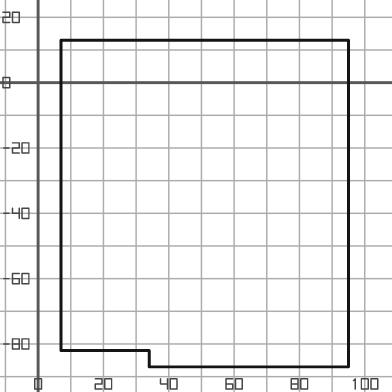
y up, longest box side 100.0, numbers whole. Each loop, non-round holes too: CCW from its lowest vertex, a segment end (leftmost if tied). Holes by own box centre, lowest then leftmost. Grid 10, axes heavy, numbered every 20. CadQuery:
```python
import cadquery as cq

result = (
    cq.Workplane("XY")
    .moveTo(34.0, -87.0)
    .lineTo(95.0, -87.0)
    .lineTo(95.0, 13.0)
    .lineTo(7.0, 13.0)
    .lineTo(7.0, -82.0)
    .lineTo(34.0, -82.0)
    .close()
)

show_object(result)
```